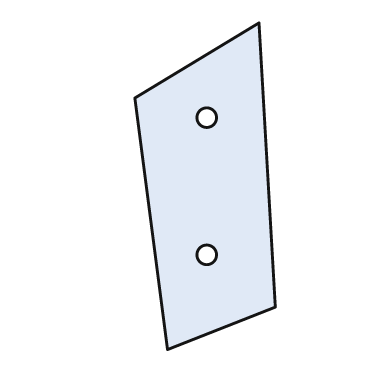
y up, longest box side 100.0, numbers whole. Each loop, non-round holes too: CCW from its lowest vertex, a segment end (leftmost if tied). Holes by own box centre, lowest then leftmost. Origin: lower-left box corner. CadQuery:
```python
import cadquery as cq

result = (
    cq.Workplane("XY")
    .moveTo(10.0, 0.0)
    .lineTo(43.0, 13.0)
    .lineTo(38.0, 100.0)
    .lineTo(0.0, 77.0)
    .close()
    .moveTo(22.0, 29.0)
    .circle(3.0)
    .moveTo(22.0, 71.0)
    .circle(3.0)
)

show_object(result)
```